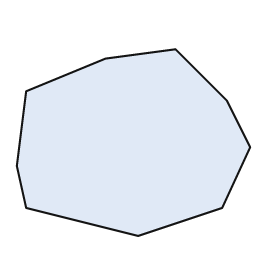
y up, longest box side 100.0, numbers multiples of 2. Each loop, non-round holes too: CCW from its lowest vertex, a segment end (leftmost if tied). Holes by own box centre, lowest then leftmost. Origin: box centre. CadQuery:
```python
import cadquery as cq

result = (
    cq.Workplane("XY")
    .moveTo(2.0, -40.0)
    .lineTo(38.0, -28.0)
    .lineTo(50.0, -2.0)
    .lineTo(40.0, 18.0)
    .lineTo(18.0, 40.0)
    .lineTo(-12.0, 36.0)
    .lineTo(-46.0, 22.0)
    .lineTo(-50.0, -10.0)
    .lineTo(-46.0, -28.0)
    .close()
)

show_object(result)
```